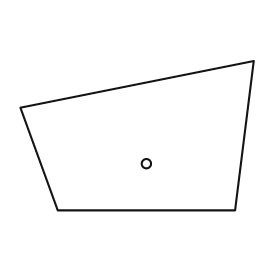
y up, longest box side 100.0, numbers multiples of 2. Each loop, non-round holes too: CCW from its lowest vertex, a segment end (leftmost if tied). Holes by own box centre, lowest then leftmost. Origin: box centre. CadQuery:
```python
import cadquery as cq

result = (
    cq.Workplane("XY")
    .moveTo(-34.0, -32.0)
    .lineTo(42.0, -32.0)
    .lineTo(50.0, 32.0)
    .lineTo(-50.0, 12.0)
    .close()
    .moveTo(4.0, -12.0)
    .circle(2.0)
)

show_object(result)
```